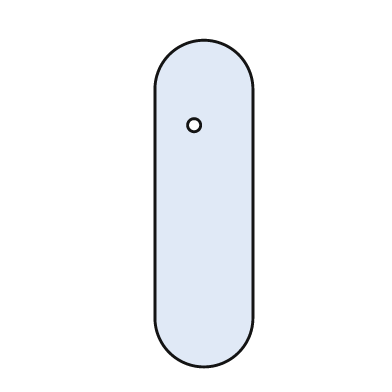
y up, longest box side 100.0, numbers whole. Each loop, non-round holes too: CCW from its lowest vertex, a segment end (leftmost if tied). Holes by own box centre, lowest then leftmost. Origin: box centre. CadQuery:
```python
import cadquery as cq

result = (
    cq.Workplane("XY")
    .moveTo(-15.0, -35.0)
    .threePointArc((0.0, -50.0), (15.0, -35.0))
    .lineTo(15.0, 35.0)
    .threePointArc((0.0, 50.0), (-15.0, 35.0))
    .close()
    .moveTo(-3.0, 24.0)
    .circle(2.0)
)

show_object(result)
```